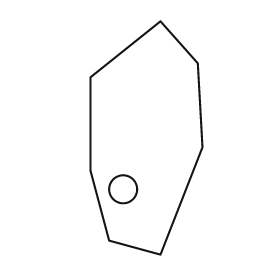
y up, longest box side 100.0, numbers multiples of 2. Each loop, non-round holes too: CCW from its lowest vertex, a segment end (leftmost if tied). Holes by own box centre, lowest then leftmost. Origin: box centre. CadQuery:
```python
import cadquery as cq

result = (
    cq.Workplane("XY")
    .moveTo(6.0, -50.0)
    .lineTo(24.0, -4.0)
    .lineTo(22.0, 32.0)
    .lineTo(6.0, 50.0)
    .lineTo(-24.0, 26.0)
    .lineTo(-24.0, -14.0)
    .lineTo(-16.0, -44.0)
    .close()
    .moveTo(-10.0, -22.0)
    .circle(6.0)
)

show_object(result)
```